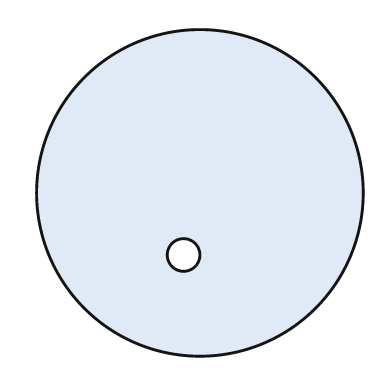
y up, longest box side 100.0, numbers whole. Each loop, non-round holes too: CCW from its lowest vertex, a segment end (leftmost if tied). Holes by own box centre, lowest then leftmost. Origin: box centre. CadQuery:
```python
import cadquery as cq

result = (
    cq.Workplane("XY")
    .moveTo(0.0, 0.0)
    .circle(50.0)
    .moveTo(-5.0, -19.0)
    .circle(5.0)
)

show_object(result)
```